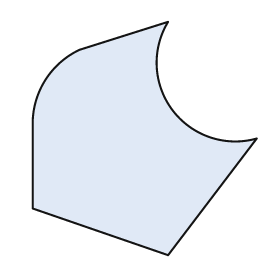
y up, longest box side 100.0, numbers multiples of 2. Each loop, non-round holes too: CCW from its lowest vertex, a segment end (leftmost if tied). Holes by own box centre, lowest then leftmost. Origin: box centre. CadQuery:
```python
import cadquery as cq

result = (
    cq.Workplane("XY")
    .moveTo(10.0, -50.0)
    .lineTo(48.0, 0.0)
    .threePointArc((12.0, 12.0), (10.0, 50.0))
    .lineTo(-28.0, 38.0)
    .threePointArc((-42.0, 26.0), (-48.0, 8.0))
    .lineTo(-48.0, -30.0)
    .close()
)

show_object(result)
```